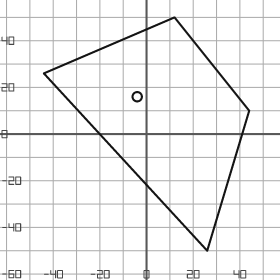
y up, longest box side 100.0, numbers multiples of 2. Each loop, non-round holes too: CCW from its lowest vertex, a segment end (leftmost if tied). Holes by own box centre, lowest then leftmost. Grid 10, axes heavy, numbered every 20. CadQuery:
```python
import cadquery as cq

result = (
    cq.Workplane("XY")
    .moveTo(26.0, -50.0)
    .lineTo(44.0, 10.0)
    .lineTo(12.0, 50.0)
    .lineTo(-44.0, 26.0)
    .close()
    .moveTo(-4.0, 16.0)
    .circle(2.0)
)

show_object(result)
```